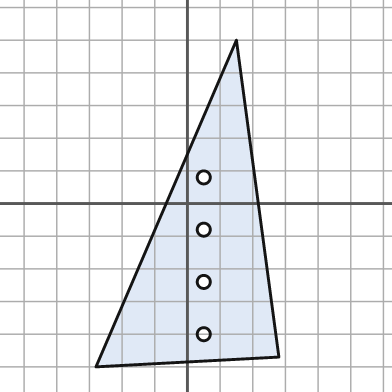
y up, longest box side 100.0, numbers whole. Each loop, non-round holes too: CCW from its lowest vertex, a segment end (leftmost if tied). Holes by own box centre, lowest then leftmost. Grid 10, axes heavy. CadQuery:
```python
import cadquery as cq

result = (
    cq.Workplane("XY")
    .moveTo(-28.0, -50.0)
    .lineTo(28.0, -47.0)
    .lineTo(15.0, 50.0)
    .close()
    .moveTo(5.0, -40.0)
    .circle(2.0)
    .moveTo(5.0, -24.0)
    .circle(2.0)
    .moveTo(5.0, -8.0)
    .circle(2.0)
    .moveTo(5.0, 8.0)
    .circle(2.0)
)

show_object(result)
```